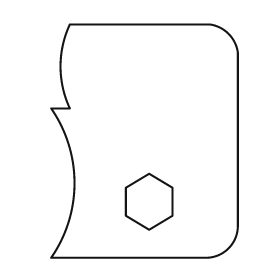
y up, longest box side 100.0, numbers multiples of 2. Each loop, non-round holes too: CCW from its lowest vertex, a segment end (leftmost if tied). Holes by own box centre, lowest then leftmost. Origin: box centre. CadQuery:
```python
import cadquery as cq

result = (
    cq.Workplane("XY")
    .moveTo(-40.0, -50.0)
    .lineTo(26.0, -50.0)
    .threePointArc((36.0, -46.0), (40.0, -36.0))
    .lineTo(40.0, 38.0)
    .threePointArc((36.0, 46.0), (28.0, 50.0))
    .lineTo(-32.0, 50.0)
    .threePointArc((-36.0, 32.0), (-32.0, 14.0))
    .lineTo(-40.0, 14.0)
    .threePointArc((-30.0, -18.0), (-40.0, -50.0))
    .close()
    .moveTo(2.0, -38.0)
    .lineTo(12.0, -32.0)
    .lineTo(12.0, -20.0)
    .lineTo(2.0, -14.0)
    .lineTo(-8.0, -20.0)
    .lineTo(-8.0, -32.0)
    .close()
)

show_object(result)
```